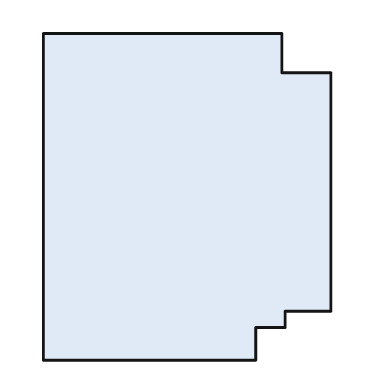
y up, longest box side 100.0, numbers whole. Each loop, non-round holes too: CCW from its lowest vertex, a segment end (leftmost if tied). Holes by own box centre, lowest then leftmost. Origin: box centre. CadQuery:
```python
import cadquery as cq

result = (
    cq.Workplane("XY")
    .moveTo(-44.0, -50.0)
    .lineTo(21.0, -50.0)
    .lineTo(21.0, -40.0)
    .lineTo(30.0, -40.0)
    .lineTo(30.0, -35.0)
    .lineTo(44.0, -35.0)
    .lineTo(44.0, 38.0)
    .lineTo(29.0, 38.0)
    .lineTo(29.0, 50.0)
    .lineTo(-44.0, 50.0)
    .close()
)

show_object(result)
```